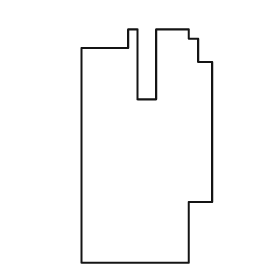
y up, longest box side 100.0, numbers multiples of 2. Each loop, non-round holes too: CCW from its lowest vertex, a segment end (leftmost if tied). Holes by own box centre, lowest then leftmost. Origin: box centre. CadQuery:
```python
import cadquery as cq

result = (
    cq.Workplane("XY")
    .moveTo(-28.0, -50.0)
    .lineTo(18.0, -50.0)
    .lineTo(18.0, -24.0)
    .lineTo(28.0, -24.0)
    .lineTo(28.0, 36.0)
    .lineTo(22.0, 36.0)
    .lineTo(22.0, 46.0)
    .lineTo(18.0, 46.0)
    .lineTo(18.0, 50.0)
    .lineTo(4.0, 50.0)
    .lineTo(4.0, 20.0)
    .lineTo(-4.0, 20.0)
    .lineTo(-4.0, 50.0)
    .lineTo(-8.0, 50.0)
    .lineTo(-8.0, 42.0)
    .lineTo(-28.0, 42.0)
    .close()
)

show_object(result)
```